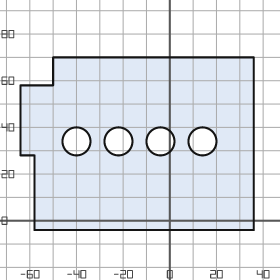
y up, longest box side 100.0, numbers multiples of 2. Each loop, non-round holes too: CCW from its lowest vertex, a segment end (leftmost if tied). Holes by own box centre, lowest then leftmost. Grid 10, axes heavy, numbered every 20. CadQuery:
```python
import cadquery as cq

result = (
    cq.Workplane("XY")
    .moveTo(-58.0, -4.0)
    .lineTo(36.0, -4.0)
    .lineTo(36.0, 70.0)
    .lineTo(-50.0, 70.0)
    .lineTo(-50.0, 58.0)
    .lineTo(-64.0, 58.0)
    .lineTo(-64.0, 28.0)
    .lineTo(-58.0, 28.0)
    .close()
    .moveTo(-40.0, 34.0)
    .circle(6.0)
    .moveTo(-22.0, 34.0)
    .circle(6.0)
    .moveTo(-4.0, 34.0)
    .circle(6.0)
    .moveTo(14.0, 34.0)
    .circle(6.0)
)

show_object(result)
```